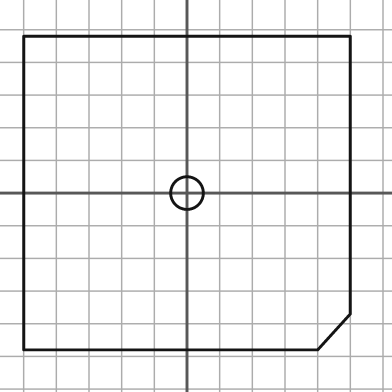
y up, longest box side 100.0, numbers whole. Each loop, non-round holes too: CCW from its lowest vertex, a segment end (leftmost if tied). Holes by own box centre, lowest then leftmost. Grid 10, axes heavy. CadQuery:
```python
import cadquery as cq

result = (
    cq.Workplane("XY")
    .moveTo(-50.0, -48.0)
    .lineTo(40.0, -48.0)
    .lineTo(50.0, -37.0)
    .lineTo(50.0, 48.0)
    .lineTo(-50.0, 48.0)
    .close()
    .moveTo(0.0, 0.0)
    .circle(5.0)
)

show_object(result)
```